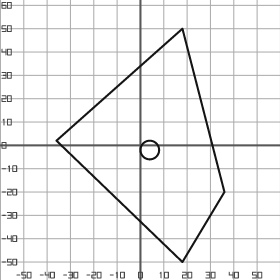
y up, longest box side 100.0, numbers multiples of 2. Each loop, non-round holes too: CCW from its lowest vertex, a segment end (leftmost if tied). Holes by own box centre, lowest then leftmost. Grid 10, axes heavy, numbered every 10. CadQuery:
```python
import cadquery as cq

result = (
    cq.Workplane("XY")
    .moveTo(18.0, -50.0)
    .lineTo(36.0, -20.0)
    .lineTo(18.0, 50.0)
    .lineTo(-36.0, 2.0)
    .close()
    .moveTo(4.0, -2.0)
    .circle(4.0)
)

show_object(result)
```